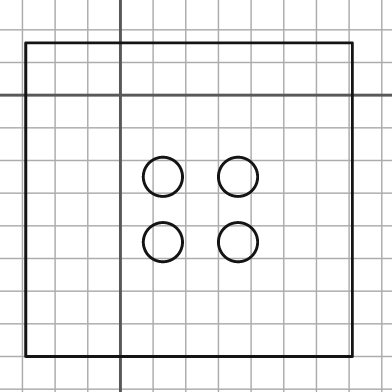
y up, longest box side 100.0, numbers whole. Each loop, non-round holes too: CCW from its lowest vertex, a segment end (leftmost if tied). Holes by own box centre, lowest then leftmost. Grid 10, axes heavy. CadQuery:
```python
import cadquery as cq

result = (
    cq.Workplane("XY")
    .moveTo(-29.0, -80.0)
    .lineTo(71.0, -80.0)
    .lineTo(71.0, 16.0)
    .lineTo(-29.0, 16.0)
    .close()
    .moveTo(13.0, -45.0)
    .circle(6.0)
    .moveTo(36.0, -45.0)
    .circle(6.0)
    .moveTo(13.0, -25.0)
    .circle(6.0)
    .moveTo(36.0, -25.0)
    .circle(6.0)
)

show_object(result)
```